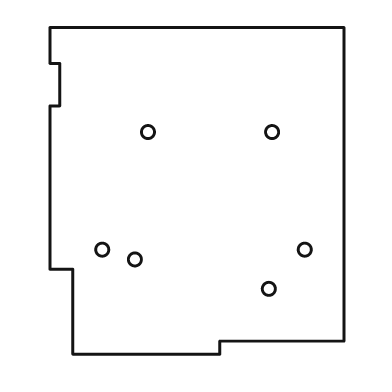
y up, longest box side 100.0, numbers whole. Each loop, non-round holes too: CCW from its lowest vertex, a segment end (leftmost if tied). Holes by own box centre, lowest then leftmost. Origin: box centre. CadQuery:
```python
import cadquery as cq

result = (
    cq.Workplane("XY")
    .moveTo(-38.0, -50.0)
    .lineTo(7.0, -50.0)
    .lineTo(7.0, -46.0)
    .lineTo(45.0, -46.0)
    .lineTo(45.0, 50.0)
    .lineTo(-45.0, 50.0)
    .lineTo(-45.0, 39.0)
    .lineTo(-42.0, 39.0)
    .lineTo(-42.0, 26.0)
    .lineTo(-45.0, 26.0)
    .lineTo(-45.0, -24.0)
    .lineTo(-38.0, -24.0)
    .close()
    .moveTo(22.0, -30.0)
    .circle(2.0)
    .moveTo(-19.0, -21.0)
    .circle(2.0)
    .moveTo(-29.0, -18.0)
    .circle(2.0)
    .moveTo(33.0, -18.0)
    .circle(2.0)
    .moveTo(-15.0, 18.0)
    .circle(2.0)
    .moveTo(23.0, 18.0)
    .circle(2.0)
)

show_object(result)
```